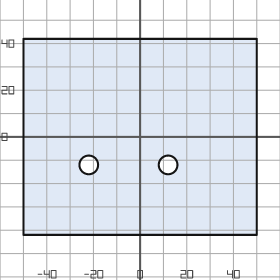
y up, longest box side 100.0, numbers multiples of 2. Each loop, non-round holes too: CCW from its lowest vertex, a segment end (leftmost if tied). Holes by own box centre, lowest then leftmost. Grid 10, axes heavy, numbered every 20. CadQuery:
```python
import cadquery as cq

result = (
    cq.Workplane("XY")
    .moveTo(-50.0, -42.0)
    .lineTo(50.0, -42.0)
    .lineTo(50.0, 42.0)
    .lineTo(-50.0, 42.0)
    .close()
    .moveTo(-22.0, -12.0)
    .circle(4.0)
    .moveTo(12.0, -12.0)
    .circle(4.0)
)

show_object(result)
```